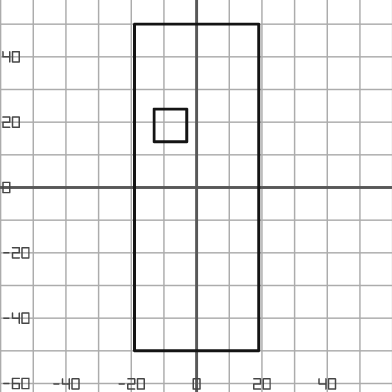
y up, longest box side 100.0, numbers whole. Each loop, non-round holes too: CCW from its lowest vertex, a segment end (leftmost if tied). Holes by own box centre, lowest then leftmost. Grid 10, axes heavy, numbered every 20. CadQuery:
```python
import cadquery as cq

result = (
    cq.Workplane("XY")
    .moveTo(-19.0, -50.0)
    .lineTo(19.0, -50.0)
    .lineTo(19.0, 50.0)
    .lineTo(-19.0, 50.0)
    .close()
    .moveTo(-13.0, 14.0)
    .lineTo(-3.0, 14.0)
    .lineTo(-3.0, 24.0)
    .lineTo(-13.0, 24.0)
    .close()
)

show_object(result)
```